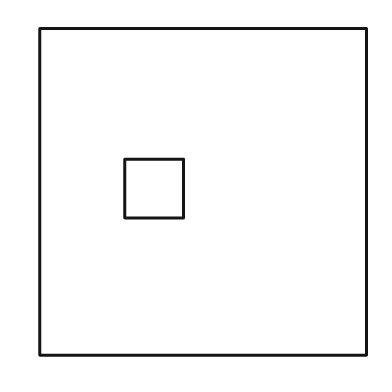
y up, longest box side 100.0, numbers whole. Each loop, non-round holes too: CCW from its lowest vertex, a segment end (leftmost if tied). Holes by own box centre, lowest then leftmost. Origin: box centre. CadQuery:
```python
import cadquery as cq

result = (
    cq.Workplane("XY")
    .moveTo(-50.0, -50.0)
    .lineTo(50.0, -50.0)
    .lineTo(50.0, 50.0)
    .lineTo(-50.0, 50.0)
    .close()
    .moveTo(-24.0, -8.0)
    .lineTo(-6.0, -8.0)
    .lineTo(-6.0, 10.0)
    .lineTo(-24.0, 10.0)
    .close()
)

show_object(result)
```